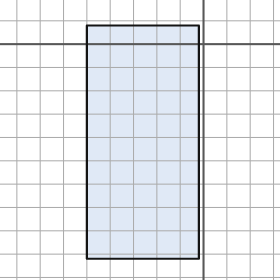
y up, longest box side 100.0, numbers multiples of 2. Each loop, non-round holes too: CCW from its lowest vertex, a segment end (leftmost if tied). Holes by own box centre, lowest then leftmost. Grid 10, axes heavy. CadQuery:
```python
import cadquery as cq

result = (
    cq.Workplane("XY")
    .moveTo(-50.0, -92.0)
    .lineTo(-2.0, -92.0)
    .lineTo(-2.0, 8.0)
    .lineTo(-50.0, 8.0)
    .close()
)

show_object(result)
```